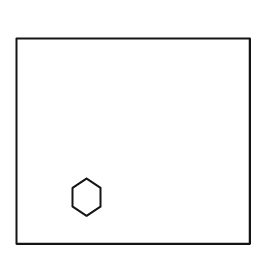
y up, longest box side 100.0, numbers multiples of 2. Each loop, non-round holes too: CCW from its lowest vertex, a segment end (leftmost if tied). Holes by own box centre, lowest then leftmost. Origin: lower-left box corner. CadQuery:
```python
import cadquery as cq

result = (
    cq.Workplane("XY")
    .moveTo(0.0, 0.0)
    .lineTo(100.0, 0.0)
    .lineTo(100.0, 88.0)
    .lineTo(0.0, 88.0)
    .close()
    .moveTo(30.0, 12.0)
    .lineTo(36.0, 16.0)
    .lineTo(36.0, 24.0)
    .lineTo(30.0, 28.0)
    .lineTo(24.0, 24.0)
    .lineTo(24.0, 16.0)
    .close()
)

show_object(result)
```